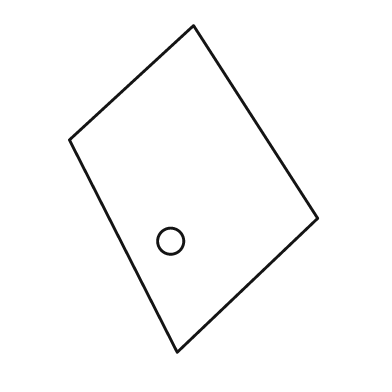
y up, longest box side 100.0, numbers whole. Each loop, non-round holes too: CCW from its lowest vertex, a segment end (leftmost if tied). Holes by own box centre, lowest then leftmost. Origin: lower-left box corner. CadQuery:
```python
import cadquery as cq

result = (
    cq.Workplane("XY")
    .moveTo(33.0, 0.0)
    .lineTo(76.0, 41.0)
    .lineTo(38.0, 100.0)
    .lineTo(0.0, 65.0)
    .close()
    .moveTo(31.0, 34.0)
    .circle(4.0)
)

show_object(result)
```